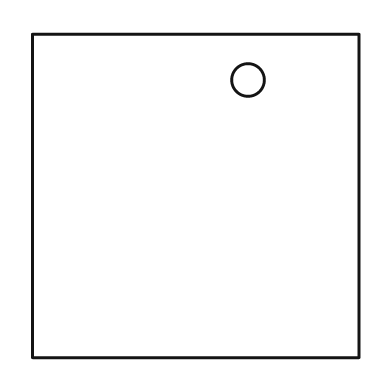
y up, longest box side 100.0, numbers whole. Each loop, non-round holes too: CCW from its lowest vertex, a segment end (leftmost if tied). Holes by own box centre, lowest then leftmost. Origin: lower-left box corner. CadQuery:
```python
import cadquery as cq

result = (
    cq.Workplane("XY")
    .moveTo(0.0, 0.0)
    .lineTo(100.0, 0.0)
    .lineTo(100.0, 99.0)
    .lineTo(0.0, 99.0)
    .close()
    .moveTo(66.0, 85.0)
    .circle(5.0)
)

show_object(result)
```